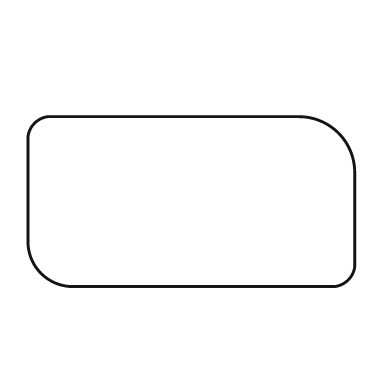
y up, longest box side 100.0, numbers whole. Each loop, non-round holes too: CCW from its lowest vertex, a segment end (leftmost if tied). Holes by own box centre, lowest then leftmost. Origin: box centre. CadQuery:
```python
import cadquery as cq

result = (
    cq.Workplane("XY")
    .moveTo(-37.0, -26.0)
    .lineTo(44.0, -26.0)
    .threePointArc((48.0, -24.0), (50.0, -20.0))
    .lineTo(50.0, 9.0)
    .threePointArc((45.0, 21.0), (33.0, 26.0))
    .lineTo(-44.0, 26.0)
    .threePointArc((-48.0, 24.0), (-50.0, 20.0))
    .lineTo(-50.0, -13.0)
    .threePointArc((-46.0, -22.0), (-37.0, -26.0))
    .close()
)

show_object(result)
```